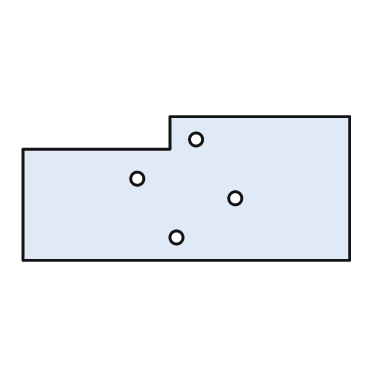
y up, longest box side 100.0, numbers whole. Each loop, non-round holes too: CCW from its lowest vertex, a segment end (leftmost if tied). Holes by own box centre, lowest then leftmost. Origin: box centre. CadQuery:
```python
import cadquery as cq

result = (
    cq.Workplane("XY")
    .moveTo(-50.0, -22.0)
    .lineTo(50.0, -22.0)
    .lineTo(50.0, 22.0)
    .lineTo(-5.0, 22.0)
    .lineTo(-5.0, 12.0)
    .lineTo(-50.0, 12.0)
    .close()
    .moveTo(-3.0, -15.0)
    .circle(2.0)
    .moveTo(15.0, -3.0)
    .circle(2.0)
    .moveTo(-15.0, 3.0)
    .circle(2.0)
    .moveTo(3.0, 15.0)
    .circle(2.0)
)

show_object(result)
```